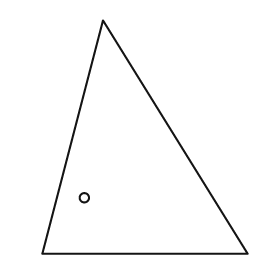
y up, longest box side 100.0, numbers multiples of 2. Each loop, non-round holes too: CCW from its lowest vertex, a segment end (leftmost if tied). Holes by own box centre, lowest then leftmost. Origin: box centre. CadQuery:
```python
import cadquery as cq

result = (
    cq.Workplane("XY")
    .moveTo(-44.0, -50.0)
    .lineTo(44.0, -50.0)
    .lineTo(-18.0, 50.0)
    .close()
    .moveTo(-26.0, -26.0)
    .circle(2.0)
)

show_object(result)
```